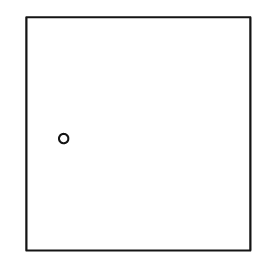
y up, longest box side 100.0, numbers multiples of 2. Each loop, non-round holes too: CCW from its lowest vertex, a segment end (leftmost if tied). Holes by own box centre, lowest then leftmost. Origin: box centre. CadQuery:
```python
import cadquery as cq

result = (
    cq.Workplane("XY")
    .moveTo(-48.0, -50.0)
    .lineTo(48.0, -50.0)
    .lineTo(48.0, 50.0)
    .lineTo(-48.0, 50.0)
    .close()
    .moveTo(-32.0, -2.0)
    .circle(2.0)
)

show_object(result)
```